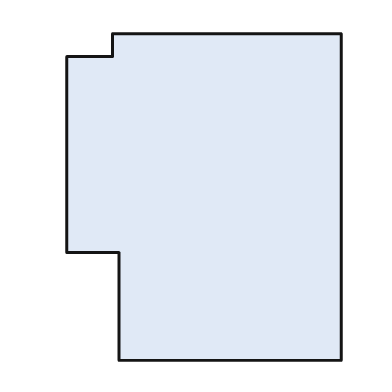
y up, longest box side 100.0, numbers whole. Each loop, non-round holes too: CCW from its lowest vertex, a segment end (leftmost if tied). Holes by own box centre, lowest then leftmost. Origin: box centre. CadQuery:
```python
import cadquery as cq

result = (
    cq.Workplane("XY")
    .moveTo(-26.0, -50.0)
    .lineTo(42.0, -50.0)
    .lineTo(42.0, 50.0)
    .lineTo(-28.0, 50.0)
    .lineTo(-28.0, 43.0)
    .lineTo(-42.0, 43.0)
    .lineTo(-42.0, -17.0)
    .lineTo(-26.0, -17.0)
    .close()
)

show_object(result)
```